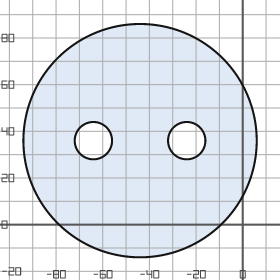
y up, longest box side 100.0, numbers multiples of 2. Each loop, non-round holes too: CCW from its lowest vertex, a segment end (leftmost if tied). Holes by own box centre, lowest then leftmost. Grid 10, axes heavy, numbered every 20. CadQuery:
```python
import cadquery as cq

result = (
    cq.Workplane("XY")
    .moveTo(-44.0, 36.0)
    .circle(50.0)
    .moveTo(-64.0, 36.0)
    .circle(8.0)
    .moveTo(-24.0, 36.0)
    .circle(8.0)
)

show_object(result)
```